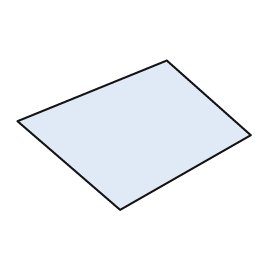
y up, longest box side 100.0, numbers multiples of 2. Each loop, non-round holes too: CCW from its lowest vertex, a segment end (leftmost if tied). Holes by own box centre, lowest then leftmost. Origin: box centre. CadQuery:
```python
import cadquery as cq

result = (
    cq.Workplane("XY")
    .moveTo(-6.0, -32.0)
    .lineTo(50.0, 0.0)
    .lineTo(14.0, 32.0)
    .lineTo(-50.0, 6.0)
    .close()
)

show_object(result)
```